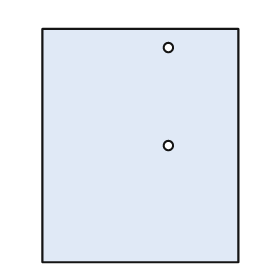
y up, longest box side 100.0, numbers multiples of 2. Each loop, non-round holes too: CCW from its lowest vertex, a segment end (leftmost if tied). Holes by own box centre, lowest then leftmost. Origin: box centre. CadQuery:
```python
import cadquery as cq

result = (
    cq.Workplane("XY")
    .moveTo(-42.0, -50.0)
    .lineTo(42.0, -50.0)
    .lineTo(42.0, 50.0)
    .lineTo(-42.0, 50.0)
    .close()
    .moveTo(12.0, 0.0)
    .circle(2.0)
    .moveTo(12.0, 42.0)
    .circle(2.0)
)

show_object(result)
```